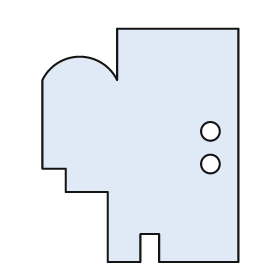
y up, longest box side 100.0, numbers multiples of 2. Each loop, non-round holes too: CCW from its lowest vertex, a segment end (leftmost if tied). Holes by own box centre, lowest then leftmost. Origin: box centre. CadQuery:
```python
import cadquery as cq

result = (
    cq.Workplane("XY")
    .moveTo(-14.0, -50.0)
    .lineTo(0.0, -50.0)
    .lineTo(0.0, -38.0)
    .lineTo(8.0, -38.0)
    .lineTo(8.0, -50.0)
    .lineTo(42.0, -50.0)
    .lineTo(42.0, 50.0)
    .lineTo(-10.0, 50.0)
    .lineTo(-10.0, 28.0)
    .threePointArc((-26.0, 38.0), (-42.0, 28.0))
    .lineTo(-42.0, -10.0)
    .lineTo(-32.0, -10.0)
    .lineTo(-32.0, -20.0)
    .lineTo(-14.0, -20.0)
    .close()
    .moveTo(30.0, -8.0)
    .circle(4.0)
    .moveTo(30.0, 6.0)
    .circle(4.0)
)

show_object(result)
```